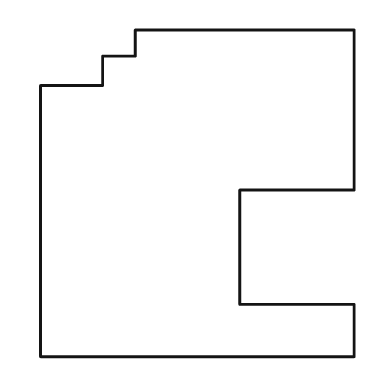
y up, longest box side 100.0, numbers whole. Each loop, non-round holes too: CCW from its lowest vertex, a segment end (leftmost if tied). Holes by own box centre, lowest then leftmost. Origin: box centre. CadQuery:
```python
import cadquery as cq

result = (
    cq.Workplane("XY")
    .moveTo(-48.0, -50.0)
    .lineTo(48.0, -50.0)
    .lineTo(48.0, -34.0)
    .lineTo(13.0, -34.0)
    .lineTo(13.0, 1.0)
    .lineTo(48.0, 1.0)
    .lineTo(48.0, 50.0)
    .lineTo(-19.0, 50.0)
    .lineTo(-19.0, 42.0)
    .lineTo(-29.0, 42.0)
    .lineTo(-29.0, 33.0)
    .lineTo(-48.0, 33.0)
    .close()
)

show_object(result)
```